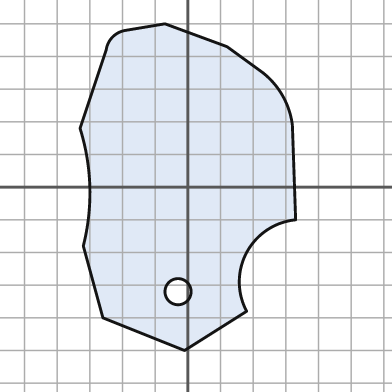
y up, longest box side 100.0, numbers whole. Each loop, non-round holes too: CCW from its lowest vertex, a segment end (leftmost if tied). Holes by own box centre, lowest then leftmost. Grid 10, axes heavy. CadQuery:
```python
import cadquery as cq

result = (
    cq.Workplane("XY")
    .moveTo(-1.0, -50.0)
    .lineTo(18.0, -38.0)
    .threePointArc((18.0, -20.0), (33.0, -10.0))
    .lineTo(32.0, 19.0)
    .threePointArc((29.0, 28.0), (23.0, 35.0))
    .lineTo(12.0, 43.0)
    .lineTo(-7.0, 50.0)
    .lineTo(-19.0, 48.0)
    .threePointArc((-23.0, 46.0), (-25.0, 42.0))
    .lineTo(-33.0, 18.0)
    .threePointArc((-30.0, 0.0), (-32.0, -18.0))
    .lineTo(-26.0, -40.0)
    .close()
    .moveTo(-3.0, -32.0)
    .circle(4.0)
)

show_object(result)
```